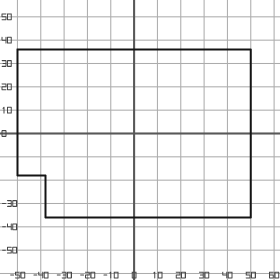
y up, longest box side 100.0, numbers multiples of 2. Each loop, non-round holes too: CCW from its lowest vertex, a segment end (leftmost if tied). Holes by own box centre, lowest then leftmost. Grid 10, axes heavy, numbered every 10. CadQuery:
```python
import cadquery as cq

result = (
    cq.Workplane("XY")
    .moveTo(-38.0, -36.0)
    .lineTo(50.0, -36.0)
    .lineTo(50.0, 36.0)
    .lineTo(-50.0, 36.0)
    .lineTo(-50.0, -18.0)
    .lineTo(-38.0, -18.0)
    .close()
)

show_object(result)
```